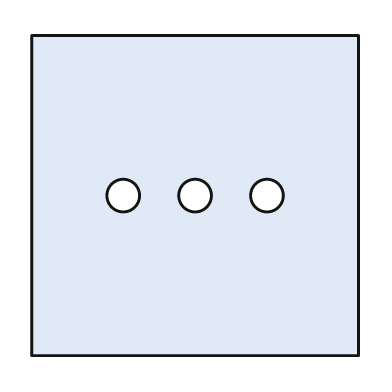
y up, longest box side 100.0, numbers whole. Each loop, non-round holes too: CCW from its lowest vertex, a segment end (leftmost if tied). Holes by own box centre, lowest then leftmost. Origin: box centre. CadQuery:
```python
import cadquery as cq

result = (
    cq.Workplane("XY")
    .moveTo(-50.0, -49.0)
    .lineTo(50.0, -49.0)
    .lineTo(50.0, 49.0)
    .lineTo(-50.0, 49.0)
    .close()
    .moveTo(-22.0, 0.0)
    .circle(5.0)
    .moveTo(0.0, 0.0)
    .circle(5.0)
    .moveTo(22.0, 0.0)
    .circle(5.0)
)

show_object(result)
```